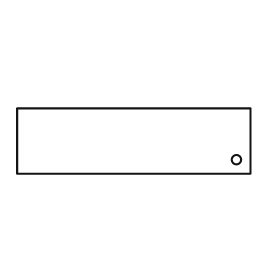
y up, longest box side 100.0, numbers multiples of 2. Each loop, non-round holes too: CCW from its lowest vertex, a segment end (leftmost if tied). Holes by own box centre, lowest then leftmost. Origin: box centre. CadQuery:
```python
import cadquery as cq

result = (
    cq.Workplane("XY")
    .moveTo(-50.0, -14.0)
    .lineTo(50.0, -14.0)
    .lineTo(50.0, 14.0)
    .lineTo(-50.0, 14.0)
    .close()
    .moveTo(44.0, -8.0)
    .circle(2.0)
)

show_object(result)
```